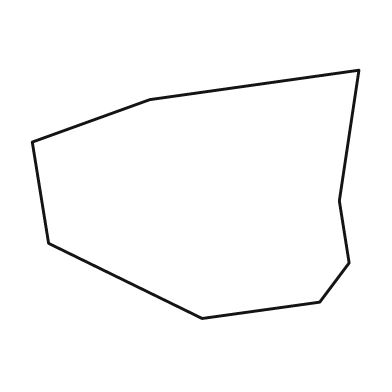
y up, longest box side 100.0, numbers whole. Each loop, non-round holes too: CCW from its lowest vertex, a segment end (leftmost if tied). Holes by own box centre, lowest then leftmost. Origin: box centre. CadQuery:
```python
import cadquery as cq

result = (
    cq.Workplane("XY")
    .moveTo(2.0, -38.0)
    .lineTo(38.0, -33.0)
    .lineTo(47.0, -21.0)
    .lineTo(44.0, -2.0)
    .lineTo(50.0, 38.0)
    .lineTo(-14.0, 29.0)
    .lineTo(-50.0, 16.0)
    .lineTo(-45.0, -15.0)
    .close()
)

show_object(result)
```